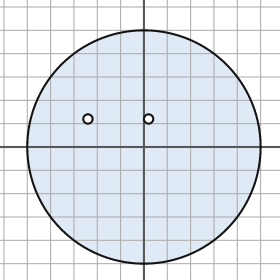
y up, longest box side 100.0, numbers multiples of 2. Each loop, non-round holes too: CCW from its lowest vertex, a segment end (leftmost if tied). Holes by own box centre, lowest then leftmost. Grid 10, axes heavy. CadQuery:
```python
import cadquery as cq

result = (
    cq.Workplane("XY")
    .moveTo(0.0, 0.0)
    .circle(50.0)
    .moveTo(-24.0, 12.0)
    .circle(2.0)
    .moveTo(2.0, 12.0)
    .circle(2.0)
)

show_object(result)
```